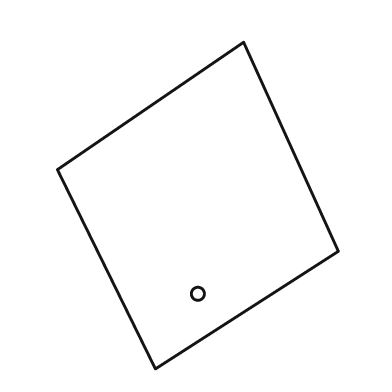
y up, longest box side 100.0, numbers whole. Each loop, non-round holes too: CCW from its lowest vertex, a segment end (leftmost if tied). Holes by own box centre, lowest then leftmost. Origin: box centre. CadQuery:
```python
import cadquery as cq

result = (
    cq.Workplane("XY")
    .moveTo(-13.0, -50.0)
    .lineTo(43.0, -14.0)
    .lineTo(14.0, 50.0)
    .lineTo(-43.0, 11.0)
    .close()
    .moveTo(0.0, -27.0)
    .circle(2.0)
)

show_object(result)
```